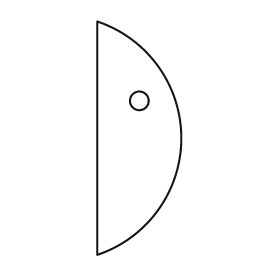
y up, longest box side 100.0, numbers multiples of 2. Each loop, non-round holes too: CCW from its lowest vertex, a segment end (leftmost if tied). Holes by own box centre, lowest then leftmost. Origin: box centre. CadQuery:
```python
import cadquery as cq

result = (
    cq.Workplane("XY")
    .moveTo(-18.0, -50.0)
    .threePointArc((18.0, 0.0), (-18.0, 50.0))
    .close()
    .moveTo(0.0, 16.0)
    .circle(4.0)
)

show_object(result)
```